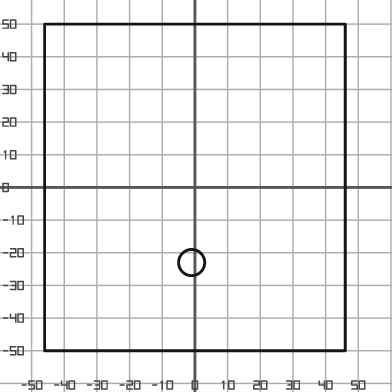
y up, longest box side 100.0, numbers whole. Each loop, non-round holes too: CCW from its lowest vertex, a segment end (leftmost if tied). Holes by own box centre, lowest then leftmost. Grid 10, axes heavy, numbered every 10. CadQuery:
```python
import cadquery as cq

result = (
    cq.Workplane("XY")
    .moveTo(-46.0, -50.0)
    .lineTo(46.0, -50.0)
    .lineTo(46.0, 50.0)
    .lineTo(-46.0, 50.0)
    .close()
    .moveTo(-1.0, -23.0)
    .circle(4.0)
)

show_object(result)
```